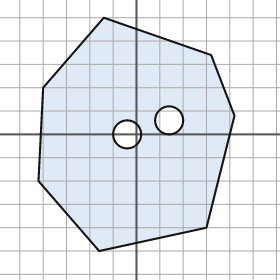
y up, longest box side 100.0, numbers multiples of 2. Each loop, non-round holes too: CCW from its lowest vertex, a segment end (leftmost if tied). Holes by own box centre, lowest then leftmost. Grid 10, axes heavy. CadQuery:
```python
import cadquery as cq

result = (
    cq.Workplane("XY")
    .moveTo(-16.0, -50.0)
    .lineTo(30.0, -40.0)
    .lineTo(42.0, 8.0)
    .lineTo(32.0, 34.0)
    .lineTo(-14.0, 50.0)
    .lineTo(-40.0, 20.0)
    .lineTo(-42.0, -20.0)
    .close()
    .moveTo(-4.0, 0.0)
    .circle(6.0)
    .moveTo(14.0, 6.0)
    .circle(6.0)
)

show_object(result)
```